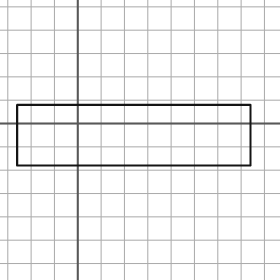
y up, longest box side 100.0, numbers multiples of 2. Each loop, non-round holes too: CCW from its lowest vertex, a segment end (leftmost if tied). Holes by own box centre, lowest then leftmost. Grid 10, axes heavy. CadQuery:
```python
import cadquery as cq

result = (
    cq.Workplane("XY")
    .moveTo(-26.0, -18.0)
    .lineTo(74.0, -18.0)
    .lineTo(74.0, 8.0)
    .lineTo(-26.0, 8.0)
    .close()
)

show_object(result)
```